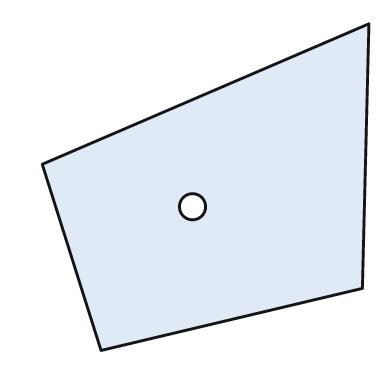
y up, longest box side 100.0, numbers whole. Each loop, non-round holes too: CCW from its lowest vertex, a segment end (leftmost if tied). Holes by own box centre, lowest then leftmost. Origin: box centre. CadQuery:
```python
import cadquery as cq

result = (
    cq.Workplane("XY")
    .moveTo(-32.0, -50.0)
    .lineTo(48.0, -31.0)
    .lineTo(50.0, 50.0)
    .lineTo(-50.0, 7.0)
    .close()
    .moveTo(-4.0, -6.0)
    .circle(4.0)
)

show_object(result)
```